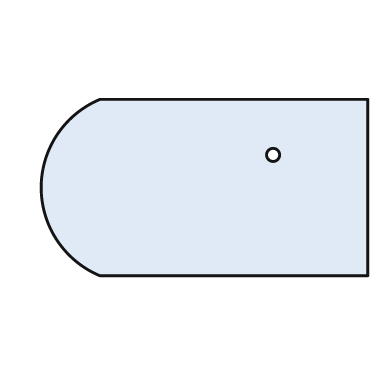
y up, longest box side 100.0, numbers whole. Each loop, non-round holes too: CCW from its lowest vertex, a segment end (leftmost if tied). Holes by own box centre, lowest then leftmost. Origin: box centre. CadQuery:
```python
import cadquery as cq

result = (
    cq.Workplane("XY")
    .moveTo(-32.0, -27.0)
    .lineTo(50.0, -27.0)
    .lineTo(50.0, 27.0)
    .lineTo(-32.0, 27.0)
    .threePointArc((-50.0, 0.0), (-32.0, -27.0))
    .close()
    .moveTo(21.0, 10.0)
    .circle(2.0)
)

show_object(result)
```